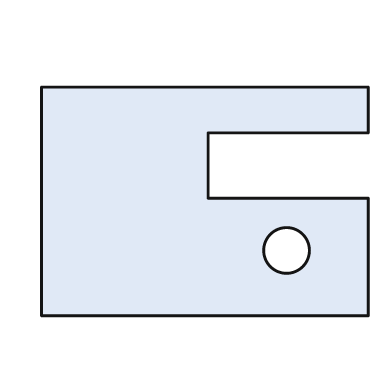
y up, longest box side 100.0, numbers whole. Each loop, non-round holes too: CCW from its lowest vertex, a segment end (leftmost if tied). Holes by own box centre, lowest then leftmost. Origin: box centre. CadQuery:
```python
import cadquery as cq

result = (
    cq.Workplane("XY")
    .moveTo(-50.0, -35.0)
    .lineTo(50.0, -35.0)
    .lineTo(50.0, 1.0)
    .lineTo(1.0, 1.0)
    .lineTo(1.0, 21.0)
    .lineTo(50.0, 21.0)
    .lineTo(50.0, 35.0)
    .lineTo(-50.0, 35.0)
    .close()
    .moveTo(25.0, -15.0)
    .circle(7.0)
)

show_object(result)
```